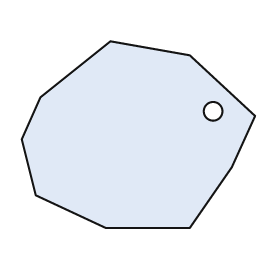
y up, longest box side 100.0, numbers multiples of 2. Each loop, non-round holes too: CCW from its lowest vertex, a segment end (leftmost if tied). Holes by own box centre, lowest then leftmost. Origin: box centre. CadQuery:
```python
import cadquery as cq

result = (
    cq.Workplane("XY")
    .moveTo(-14.0, -40.0)
    .lineTo(22.0, -40.0)
    .lineTo(40.0, -14.0)
    .lineTo(50.0, 8.0)
    .lineTo(22.0, 34.0)
    .lineTo(-12.0, 40.0)
    .lineTo(-42.0, 16.0)
    .lineTo(-50.0, -2.0)
    .lineTo(-44.0, -26.0)
    .close()
    .moveTo(32.0, 10.0)
    .circle(4.0)
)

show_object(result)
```